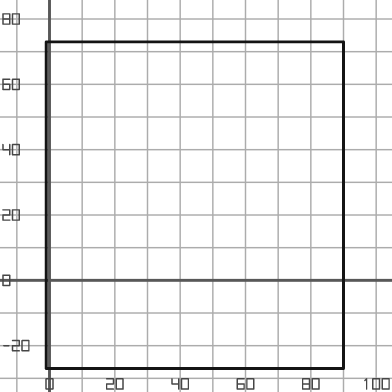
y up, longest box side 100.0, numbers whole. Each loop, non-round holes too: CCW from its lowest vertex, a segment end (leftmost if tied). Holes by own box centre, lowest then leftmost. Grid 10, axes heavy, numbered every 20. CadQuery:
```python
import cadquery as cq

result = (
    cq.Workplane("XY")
    .moveTo(-1.0, -27.0)
    .lineTo(90.0, -27.0)
    .lineTo(90.0, 73.0)
    .lineTo(-1.0, 73.0)
    .close()
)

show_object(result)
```